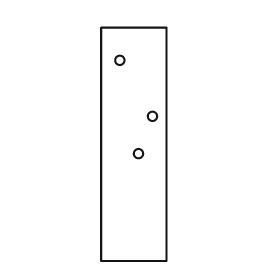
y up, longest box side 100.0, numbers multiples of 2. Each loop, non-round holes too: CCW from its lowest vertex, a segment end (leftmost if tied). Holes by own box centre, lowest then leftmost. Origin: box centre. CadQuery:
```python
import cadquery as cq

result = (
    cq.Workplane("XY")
    .moveTo(-14.0, -50.0)
    .lineTo(14.0, -50.0)
    .lineTo(14.0, 50.0)
    .lineTo(-14.0, 50.0)
    .close()
    .moveTo(2.0, -4.0)
    .circle(2.0)
    .moveTo(8.0, 12.0)
    .circle(2.0)
    .moveTo(-6.0, 36.0)
    .circle(2.0)
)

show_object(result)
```